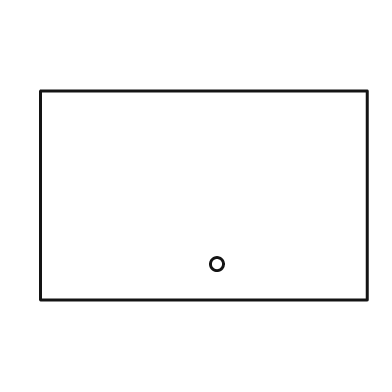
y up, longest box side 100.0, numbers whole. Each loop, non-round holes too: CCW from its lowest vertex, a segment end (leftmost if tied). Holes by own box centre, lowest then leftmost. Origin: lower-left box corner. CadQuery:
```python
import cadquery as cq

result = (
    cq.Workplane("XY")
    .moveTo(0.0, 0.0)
    .lineTo(100.0, 0.0)
    .lineTo(100.0, 64.0)
    .lineTo(0.0, 64.0)
    .close()
    .moveTo(54.0, 11.0)
    .circle(2.0)
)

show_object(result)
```